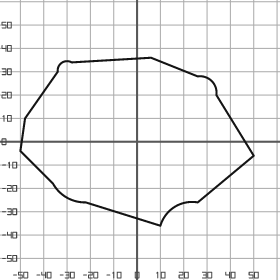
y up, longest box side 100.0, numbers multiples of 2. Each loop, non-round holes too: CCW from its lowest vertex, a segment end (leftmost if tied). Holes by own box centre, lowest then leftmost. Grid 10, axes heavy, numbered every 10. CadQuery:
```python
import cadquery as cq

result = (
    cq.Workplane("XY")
    .moveTo(10.0, -36.0)
    .threePointArc((16.0, -28.0), (26.0, -26.0))
    .lineTo(50.0, -6.0)
    .lineTo(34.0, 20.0)
    .threePointArc((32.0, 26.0), (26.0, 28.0))
    .lineTo(6.0, 36.0)
    .lineTo(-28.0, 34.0)
    .threePointArc((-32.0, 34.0), (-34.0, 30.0))
    .lineTo(-48.0, 10.0)
    .lineTo(-50.0, -4.0)
    .lineTo(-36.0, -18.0)
    .threePointArc((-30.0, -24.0), (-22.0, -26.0))
    .close()
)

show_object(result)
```